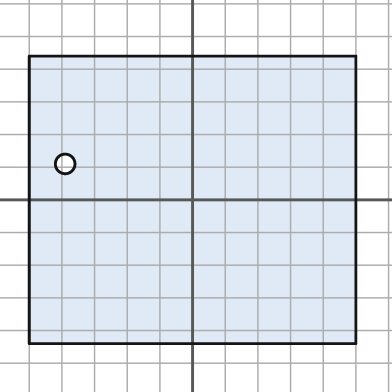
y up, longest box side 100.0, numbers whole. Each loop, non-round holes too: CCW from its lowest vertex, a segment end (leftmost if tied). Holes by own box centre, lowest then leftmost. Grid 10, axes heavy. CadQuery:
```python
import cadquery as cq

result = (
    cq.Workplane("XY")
    .moveTo(-50.0, -44.0)
    .lineTo(50.0, -44.0)
    .lineTo(50.0, 44.0)
    .lineTo(-50.0, 44.0)
    .close()
    .moveTo(-39.0, 11.0)
    .circle(3.0)
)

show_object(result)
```